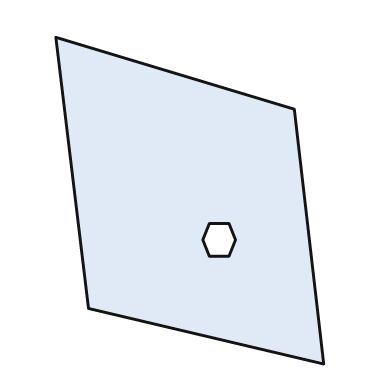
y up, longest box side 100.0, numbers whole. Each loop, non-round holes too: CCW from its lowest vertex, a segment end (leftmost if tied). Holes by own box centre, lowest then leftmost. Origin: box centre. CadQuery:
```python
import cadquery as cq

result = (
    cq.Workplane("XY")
    .moveTo(41.0, -50.0)
    .lineTo(32.0, 28.0)
    .lineTo(-41.0, 50.0)
    .lineTo(-31.0, -33.0)
    .close()
    .moveTo(6.0, -17.0)
    .lineTo(12.0, -17.0)
    .lineTo(14.0, -12.0)
    .lineTo(12.0, -7.0)
    .lineTo(6.0, -7.0)
    .lineTo(4.0, -12.0)
    .close()
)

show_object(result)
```